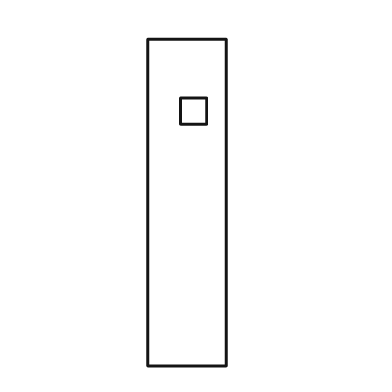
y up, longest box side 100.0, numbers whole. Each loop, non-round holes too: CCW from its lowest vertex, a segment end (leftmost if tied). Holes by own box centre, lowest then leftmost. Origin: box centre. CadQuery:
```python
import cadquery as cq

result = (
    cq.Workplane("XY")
    .moveTo(-12.0, -50.0)
    .lineTo(12.0, -50.0)
    .lineTo(12.0, 50.0)
    .lineTo(-12.0, 50.0)
    .close()
    .moveTo(-2.0, 24.0)
    .lineTo(6.0, 24.0)
    .lineTo(6.0, 32.0)
    .lineTo(-2.0, 32.0)
    .close()
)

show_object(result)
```